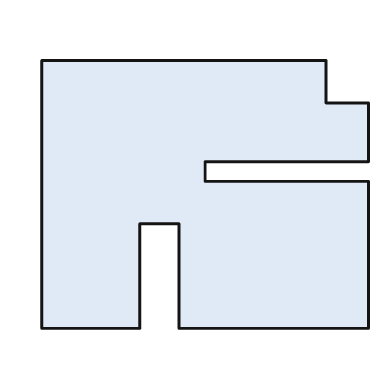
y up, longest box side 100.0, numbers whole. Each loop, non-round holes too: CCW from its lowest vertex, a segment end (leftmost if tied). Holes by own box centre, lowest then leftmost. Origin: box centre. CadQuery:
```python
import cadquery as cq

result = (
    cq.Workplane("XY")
    .moveTo(-50.0, -41.0)
    .lineTo(-20.0, -41.0)
    .lineTo(-20.0, -9.0)
    .lineTo(-8.0, -9.0)
    .lineTo(-8.0, -41.0)
    .lineTo(50.0, -41.0)
    .lineTo(50.0, 4.0)
    .lineTo(0.0, 4.0)
    .lineTo(0.0, 10.0)
    .lineTo(50.0, 10.0)
    .lineTo(50.0, 28.0)
    .lineTo(37.0, 28.0)
    .lineTo(37.0, 41.0)
    .lineTo(-50.0, 41.0)
    .close()
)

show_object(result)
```